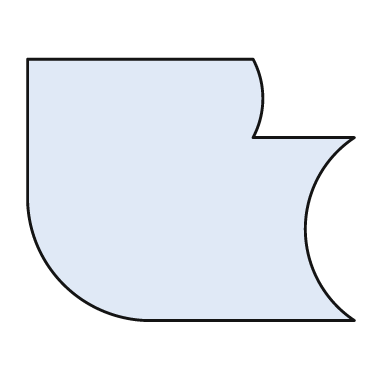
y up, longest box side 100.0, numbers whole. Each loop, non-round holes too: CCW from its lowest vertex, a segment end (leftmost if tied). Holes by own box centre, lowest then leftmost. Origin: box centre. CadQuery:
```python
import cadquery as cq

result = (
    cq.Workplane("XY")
    .moveTo(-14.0, -40.0)
    .lineTo(50.0, -40.0)
    .threePointArc((35.0, -12.0), (50.0, 16.0))
    .lineTo(19.0, 16.0)
    .threePointArc((22.0, 28.0), (19.0, 40.0))
    .lineTo(-50.0, 40.0)
    .lineTo(-50.0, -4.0)
    .threePointArc((-39.0, -29.0), (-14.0, -40.0))
    .close()
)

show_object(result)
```